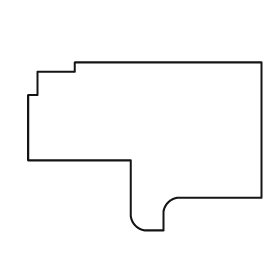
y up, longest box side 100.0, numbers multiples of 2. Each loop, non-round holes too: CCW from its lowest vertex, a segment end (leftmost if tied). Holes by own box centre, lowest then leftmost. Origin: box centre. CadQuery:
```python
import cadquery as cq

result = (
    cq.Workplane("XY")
    .moveTo(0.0, -36.0)
    .lineTo(8.0, -36.0)
    .lineTo(8.0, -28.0)
    .threePointArc((10.0, -24.0), (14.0, -22.0))
    .lineTo(50.0, -22.0)
    .lineTo(50.0, 36.0)
    .lineTo(-30.0, 36.0)
    .lineTo(-30.0, 32.0)
    .lineTo(-46.0, 32.0)
    .lineTo(-46.0, 22.0)
    .lineTo(-50.0, 22.0)
    .lineTo(-50.0, -6.0)
    .lineTo(-6.0, -6.0)
    .lineTo(-6.0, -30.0)
    .threePointArc((-4.0, -34.0), (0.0, -36.0))
    .close()
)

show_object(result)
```